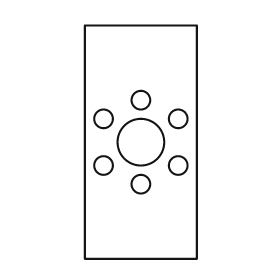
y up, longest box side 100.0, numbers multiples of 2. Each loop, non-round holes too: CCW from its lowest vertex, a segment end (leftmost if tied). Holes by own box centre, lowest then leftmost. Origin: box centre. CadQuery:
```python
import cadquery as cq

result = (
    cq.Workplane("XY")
    .moveTo(-24.0, -50.0)
    .lineTo(24.0, -50.0)
    .lineTo(24.0, 50.0)
    .lineTo(-24.0, 50.0)
    .close()
    .moveTo(0.0, -18.0)
    .circle(4.0)
    .moveTo(-16.0, -10.0)
    .circle(4.0)
    .moveTo(16.0, -10.0)
    .circle(4.0)
    .moveTo(0.0, 0.0)
    .circle(10.0)
    .moveTo(-16.0, 10.0)
    .circle(4.0)
    .moveTo(16.0, 10.0)
    .circle(4.0)
    .moveTo(0.0, 18.0)
    .circle(4.0)
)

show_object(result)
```